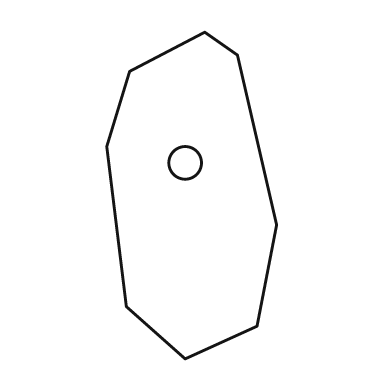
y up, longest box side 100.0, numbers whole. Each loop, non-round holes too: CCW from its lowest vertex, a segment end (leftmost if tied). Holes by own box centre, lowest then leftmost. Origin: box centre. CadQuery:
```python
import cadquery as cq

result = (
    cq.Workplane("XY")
    .moveTo(-2.0, -50.0)
    .lineTo(20.0, -40.0)
    .lineTo(26.0, -9.0)
    .lineTo(14.0, 43.0)
    .lineTo(4.0, 50.0)
    .lineTo(-19.0, 38.0)
    .lineTo(-26.0, 15.0)
    .lineTo(-20.0, -34.0)
    .close()
    .moveTo(-2.0, 10.0)
    .circle(5.0)
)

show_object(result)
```